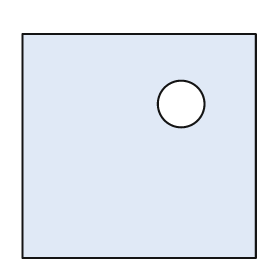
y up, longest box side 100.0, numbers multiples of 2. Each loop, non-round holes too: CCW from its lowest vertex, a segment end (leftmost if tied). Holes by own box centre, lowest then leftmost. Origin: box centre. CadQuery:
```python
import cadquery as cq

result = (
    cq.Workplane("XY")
    .moveTo(-50.0, -48.0)
    .lineTo(50.0, -48.0)
    .lineTo(50.0, 48.0)
    .lineTo(-50.0, 48.0)
    .close()
    .moveTo(18.0, 18.0)
    .circle(10.0)
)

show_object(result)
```